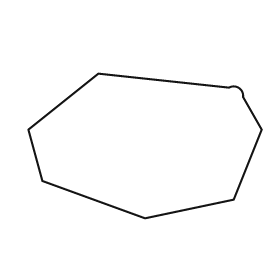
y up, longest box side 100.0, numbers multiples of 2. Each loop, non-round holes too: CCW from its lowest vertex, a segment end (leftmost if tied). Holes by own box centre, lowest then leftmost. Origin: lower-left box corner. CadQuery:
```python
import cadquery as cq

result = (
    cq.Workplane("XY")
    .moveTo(50.0, 0.0)
    .lineTo(88.0, 8.0)
    .lineTo(100.0, 38.0)
    .lineTo(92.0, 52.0)
    .threePointArc((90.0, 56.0), (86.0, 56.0))
    .lineTo(30.0, 62.0)
    .lineTo(0.0, 38.0)
    .lineTo(6.0, 16.0)
    .close()
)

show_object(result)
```